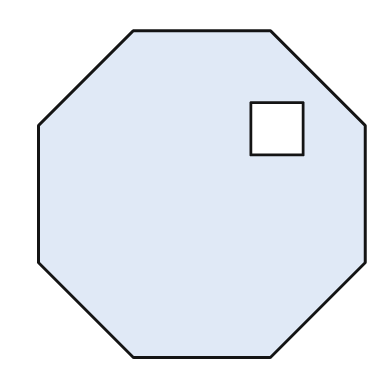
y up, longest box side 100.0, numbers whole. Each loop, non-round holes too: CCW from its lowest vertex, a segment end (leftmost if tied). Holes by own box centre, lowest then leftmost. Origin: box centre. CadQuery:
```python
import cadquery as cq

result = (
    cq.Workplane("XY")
    .moveTo(-21.0, -50.0)
    .lineTo(21.0, -50.0)
    .lineTo(50.0, -21.0)
    .lineTo(50.0, 21.0)
    .lineTo(21.0, 50.0)
    .lineTo(-21.0, 50.0)
    .lineTo(-50.0, 21.0)
    .lineTo(-50.0, -21.0)
    .close()
    .moveTo(15.0, 12.0)
    .lineTo(31.0, 12.0)
    .lineTo(31.0, 28.0)
    .lineTo(15.0, 28.0)
    .close()
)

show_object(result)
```